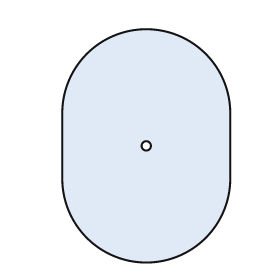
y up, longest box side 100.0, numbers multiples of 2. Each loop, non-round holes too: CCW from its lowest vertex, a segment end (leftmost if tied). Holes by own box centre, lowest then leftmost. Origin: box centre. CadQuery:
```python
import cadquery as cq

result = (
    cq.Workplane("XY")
    .moveTo(-36.0, -14.0)
    .threePointArc((0.0, -50.0), (36.0, -14.0))
    .lineTo(36.0, 14.0)
    .threePointArc((0.0, 50.0), (-36.0, 14.0))
    .close()
    .moveTo(0.0, 0.0)
    .circle(2.0)
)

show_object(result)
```